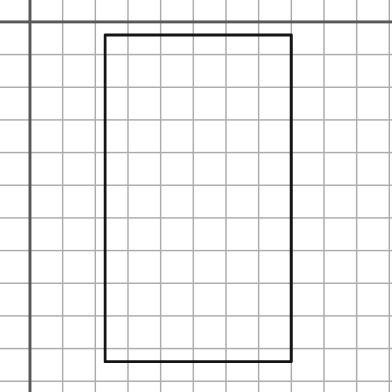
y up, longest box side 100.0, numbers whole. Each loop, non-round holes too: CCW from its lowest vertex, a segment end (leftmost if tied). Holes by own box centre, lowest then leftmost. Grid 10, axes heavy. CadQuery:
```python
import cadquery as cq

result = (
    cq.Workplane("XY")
    .moveTo(23.0, -104.0)
    .lineTo(80.0, -104.0)
    .lineTo(80.0, -4.0)
    .lineTo(23.0, -4.0)
    .close()
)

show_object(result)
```